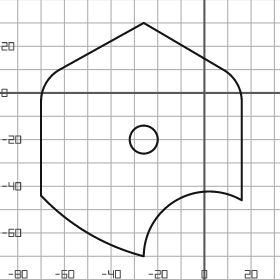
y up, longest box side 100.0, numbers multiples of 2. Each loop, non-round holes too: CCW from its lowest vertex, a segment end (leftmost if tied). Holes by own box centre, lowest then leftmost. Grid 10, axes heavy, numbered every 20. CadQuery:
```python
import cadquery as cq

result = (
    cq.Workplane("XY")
    .moveTo(-26.0, -70.0)
    .threePointArc((-12.0, -46.0), (16.0, -46.0))
    .lineTo(16.0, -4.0)
    .threePointArc((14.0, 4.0), (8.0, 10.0))
    .lineTo(-26.0, 30.0)
    .lineTo(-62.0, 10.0)
    .threePointArc((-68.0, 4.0), (-70.0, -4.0))
    .lineTo(-70.0, -44.0)
    .threePointArc((-50.0, -60.0), (-26.0, -70.0))
    .close()
    .moveTo(-26.0, -20.0)
    .circle(6.0)
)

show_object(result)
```